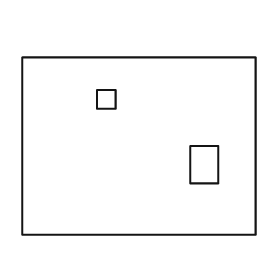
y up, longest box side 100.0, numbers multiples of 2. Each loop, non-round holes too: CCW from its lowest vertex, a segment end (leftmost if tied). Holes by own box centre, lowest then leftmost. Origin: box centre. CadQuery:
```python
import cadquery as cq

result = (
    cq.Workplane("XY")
    .moveTo(-50.0, -38.0)
    .lineTo(50.0, -38.0)
    .lineTo(50.0, 38.0)
    .lineTo(-50.0, 38.0)
    .close()
    .moveTo(22.0, -16.0)
    .lineTo(34.0, -16.0)
    .lineTo(34.0, 0.0)
    .lineTo(22.0, 0.0)
    .close()
    .moveTo(-18.0, 16.0)
    .lineTo(-10.0, 16.0)
    .lineTo(-10.0, 24.0)
    .lineTo(-18.0, 24.0)
    .close()
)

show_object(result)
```